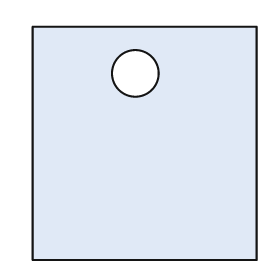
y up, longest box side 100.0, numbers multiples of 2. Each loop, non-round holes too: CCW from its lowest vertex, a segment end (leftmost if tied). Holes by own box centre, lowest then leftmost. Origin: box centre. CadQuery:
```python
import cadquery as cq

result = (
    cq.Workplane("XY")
    .moveTo(-48.0, -50.0)
    .lineTo(48.0, -50.0)
    .lineTo(48.0, 50.0)
    .lineTo(-48.0, 50.0)
    .close()
    .moveTo(-4.0, 30.0)
    .circle(10.0)
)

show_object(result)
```